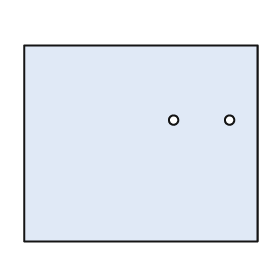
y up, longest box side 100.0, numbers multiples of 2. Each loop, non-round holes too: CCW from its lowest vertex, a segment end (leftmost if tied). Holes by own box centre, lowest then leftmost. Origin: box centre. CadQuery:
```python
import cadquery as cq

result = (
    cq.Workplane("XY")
    .moveTo(-50.0, -42.0)
    .lineTo(50.0, -42.0)
    .lineTo(50.0, 42.0)
    .lineTo(-50.0, 42.0)
    .close()
    .moveTo(14.0, 10.0)
    .circle(2.0)
    .moveTo(38.0, 10.0)
    .circle(2.0)
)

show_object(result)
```